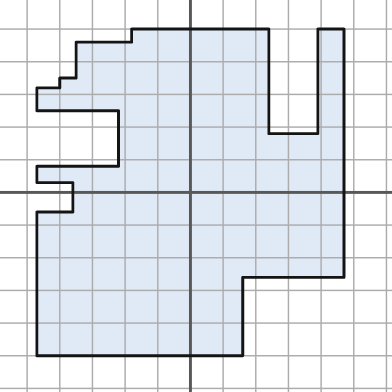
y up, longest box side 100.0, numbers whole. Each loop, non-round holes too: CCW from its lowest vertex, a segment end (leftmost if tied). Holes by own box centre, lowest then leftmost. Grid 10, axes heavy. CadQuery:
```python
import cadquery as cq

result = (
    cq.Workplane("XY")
    .moveTo(-47.0, -50.0)
    .lineTo(16.0, -50.0)
    .lineTo(16.0, -26.0)
    .lineTo(47.0, -26.0)
    .lineTo(47.0, 50.0)
    .lineTo(39.0, 50.0)
    .lineTo(39.0, 18.0)
    .lineTo(24.0, 18.0)
    .lineTo(24.0, 50.0)
    .lineTo(-18.0, 50.0)
    .lineTo(-18.0, 46.0)
    .lineTo(-35.0, 46.0)
    .lineTo(-35.0, 35.0)
    .lineTo(-40.0, 35.0)
    .lineTo(-40.0, 32.0)
    .lineTo(-47.0, 32.0)
    .lineTo(-47.0, 25.0)
    .lineTo(-22.0, 25.0)
    .lineTo(-22.0, 8.0)
    .lineTo(-47.0, 8.0)
    .lineTo(-47.0, 3.0)
    .lineTo(-36.0, 3.0)
    .lineTo(-36.0, -6.0)
    .lineTo(-47.0, -6.0)
    .close()
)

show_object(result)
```